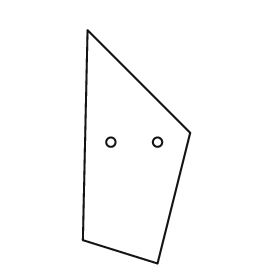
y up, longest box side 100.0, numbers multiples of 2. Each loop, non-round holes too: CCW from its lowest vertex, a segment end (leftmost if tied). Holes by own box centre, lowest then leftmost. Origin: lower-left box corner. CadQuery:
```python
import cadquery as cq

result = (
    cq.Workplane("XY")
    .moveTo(32.0, 0.0)
    .lineTo(46.0, 56.0)
    .lineTo(2.0, 100.0)
    .lineTo(0.0, 10.0)
    .close()
    .moveTo(12.0, 52.0)
    .circle(2.0)
    .moveTo(32.0, 52.0)
    .circle(2.0)
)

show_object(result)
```